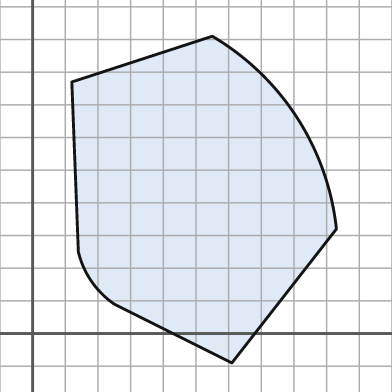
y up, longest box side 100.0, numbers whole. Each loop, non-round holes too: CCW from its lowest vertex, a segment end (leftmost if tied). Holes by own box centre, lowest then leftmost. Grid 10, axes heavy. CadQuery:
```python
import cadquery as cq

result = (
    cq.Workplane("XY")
    .moveTo(61.0, -9.0)
    .lineTo(93.0, 32.0)
    .threePointArc((81.0, 66.0), (55.0, 91.0))
    .lineTo(12.0, 77.0)
    .lineTo(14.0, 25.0)
    .threePointArc((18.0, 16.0), (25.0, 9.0))
    .close()
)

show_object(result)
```